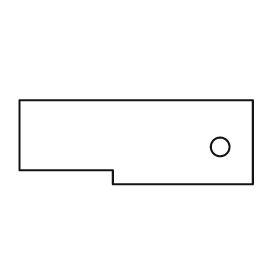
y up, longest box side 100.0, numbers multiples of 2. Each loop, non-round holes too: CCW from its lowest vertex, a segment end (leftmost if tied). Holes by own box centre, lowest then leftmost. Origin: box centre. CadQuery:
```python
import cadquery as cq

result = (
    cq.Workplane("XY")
    .moveTo(-10.0, -18.0)
    .lineTo(50.0, -18.0)
    .lineTo(50.0, 18.0)
    .lineTo(-50.0, 18.0)
    .lineTo(-50.0, -12.0)
    .lineTo(-10.0, -12.0)
    .close()
    .moveTo(36.0, -2.0)
    .circle(4.0)
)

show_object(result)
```